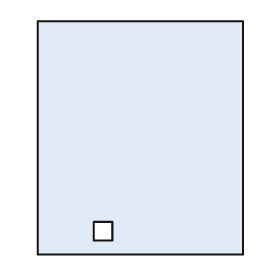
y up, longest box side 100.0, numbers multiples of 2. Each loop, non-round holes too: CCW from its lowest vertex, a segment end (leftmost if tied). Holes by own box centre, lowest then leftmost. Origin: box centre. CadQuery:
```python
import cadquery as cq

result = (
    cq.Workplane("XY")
    .moveTo(-44.0, -50.0)
    .lineTo(44.0, -50.0)
    .lineTo(44.0, 50.0)
    .lineTo(-44.0, 50.0)
    .close()
    .moveTo(-20.0, -44.0)
    .lineTo(-12.0, -44.0)
    .lineTo(-12.0, -36.0)
    .lineTo(-20.0, -36.0)
    .close()
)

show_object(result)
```